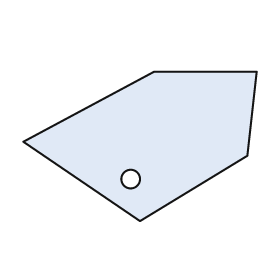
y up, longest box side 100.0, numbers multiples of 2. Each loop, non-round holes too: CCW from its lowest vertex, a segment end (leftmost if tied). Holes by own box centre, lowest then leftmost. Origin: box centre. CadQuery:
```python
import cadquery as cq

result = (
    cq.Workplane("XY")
    .moveTo(0.0, -32.0)
    .lineTo(46.0, -4.0)
    .lineTo(50.0, 32.0)
    .lineTo(6.0, 32.0)
    .lineTo(-50.0, 2.0)
    .close()
    .moveTo(-4.0, -14.0)
    .circle(4.0)
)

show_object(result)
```